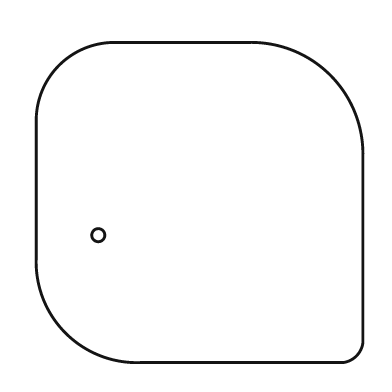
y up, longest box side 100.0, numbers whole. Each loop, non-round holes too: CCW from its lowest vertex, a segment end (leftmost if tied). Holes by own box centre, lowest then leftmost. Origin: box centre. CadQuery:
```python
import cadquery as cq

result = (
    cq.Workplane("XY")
    .moveTo(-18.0, -49.0)
    .lineTo(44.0, -49.0)
    .threePointArc((48.0, -47.0), (50.0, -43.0))
    .lineTo(50.0, 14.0)
    .threePointArc((40.0, 39.0), (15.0, 49.0))
    .lineTo(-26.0, 49.0)
    .threePointArc((-43.0, 42.0), (-50.0, 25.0))
    .lineTo(-50.0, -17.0)
    .threePointArc((-41.0, -40.0), (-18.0, -49.0))
    .close()
    .moveTo(-31.0, -10.0)
    .circle(2.0)
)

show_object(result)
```